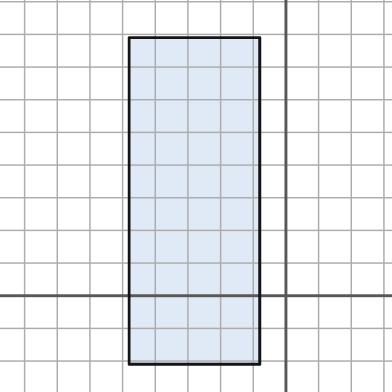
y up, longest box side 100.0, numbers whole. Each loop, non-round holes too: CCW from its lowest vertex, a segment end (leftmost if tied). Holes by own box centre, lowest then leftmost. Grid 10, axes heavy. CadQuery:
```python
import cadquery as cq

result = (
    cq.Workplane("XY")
    .moveTo(-48.0, -21.0)
    .lineTo(-8.0, -21.0)
    .lineTo(-8.0, 79.0)
    .lineTo(-48.0, 79.0)
    .close()
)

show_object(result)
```